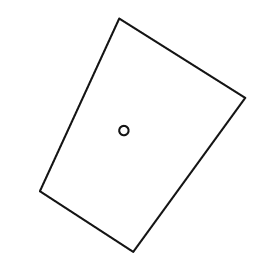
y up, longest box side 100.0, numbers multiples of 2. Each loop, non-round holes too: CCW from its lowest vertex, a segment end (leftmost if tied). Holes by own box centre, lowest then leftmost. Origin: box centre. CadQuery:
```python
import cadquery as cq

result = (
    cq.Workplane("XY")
    .moveTo(-4.0, -50.0)
    .lineTo(44.0, 16.0)
    .lineTo(-10.0, 50.0)
    .lineTo(-44.0, -24.0)
    .close()
    .moveTo(-8.0, 2.0)
    .circle(2.0)
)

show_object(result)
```